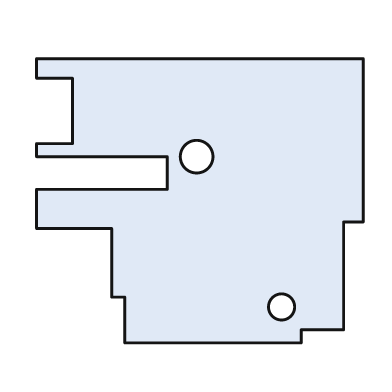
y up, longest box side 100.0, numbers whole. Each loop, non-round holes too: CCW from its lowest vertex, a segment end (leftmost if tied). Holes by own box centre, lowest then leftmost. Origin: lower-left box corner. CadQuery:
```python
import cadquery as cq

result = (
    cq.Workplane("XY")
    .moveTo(27.0, 0.0)
    .lineTo(81.0, 0.0)
    .lineTo(81.0, 4.0)
    .lineTo(94.0, 4.0)
    .lineTo(94.0, 37.0)
    .lineTo(100.0, 37.0)
    .lineTo(100.0, 87.0)
    .lineTo(0.0, 87.0)
    .lineTo(0.0, 81.0)
    .lineTo(11.0, 81.0)
    .lineTo(11.0, 61.0)
    .lineTo(0.0, 61.0)
    .lineTo(0.0, 57.0)
    .lineTo(40.0, 57.0)
    .lineTo(40.0, 47.0)
    .lineTo(0.0, 47.0)
    .lineTo(0.0, 35.0)
    .lineTo(23.0, 35.0)
    .lineTo(23.0, 14.0)
    .lineTo(27.0, 14.0)
    .close()
    .moveTo(75.0, 11.0)
    .circle(4.0)
    .moveTo(49.0, 57.0)
    .circle(5.0)
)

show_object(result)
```